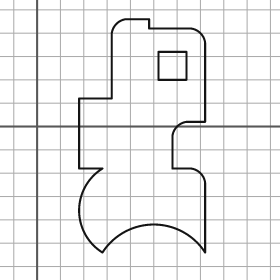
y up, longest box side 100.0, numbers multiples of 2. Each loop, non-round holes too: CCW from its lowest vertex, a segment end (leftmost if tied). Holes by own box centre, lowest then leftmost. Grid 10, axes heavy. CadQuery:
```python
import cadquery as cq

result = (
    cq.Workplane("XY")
    .moveTo(28.0, -54.0)
    .threePointArc((50.0, -42.0), (72.0, -54.0))
    .lineTo(72.0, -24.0)
    .threePointArc((70.0, -20.0), (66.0, -18.0))
    .lineTo(58.0, -18.0)
    .lineTo(58.0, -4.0)
    .threePointArc((60.0, 0.0), (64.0, 2.0))
    .lineTo(72.0, 2.0)
    .lineTo(72.0, 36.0)
    .threePointArc((70.0, 40.0), (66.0, 42.0))
    .lineTo(48.0, 42.0)
    .lineTo(48.0, 46.0)
    .lineTo(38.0, 46.0)
    .threePointArc((34.0, 44.0), (32.0, 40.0))
    .lineTo(32.0, 12.0)
    .lineTo(18.0, 12.0)
    .lineTo(18.0, -18.0)
    .lineTo(28.0, -18.0)
    .threePointArc((18.0, -36.0), (28.0, -54.0))
    .close()
    .moveTo(52.0, 20.0)
    .lineTo(64.0, 20.0)
    .lineTo(64.0, 32.0)
    .lineTo(52.0, 32.0)
    .close()
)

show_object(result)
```